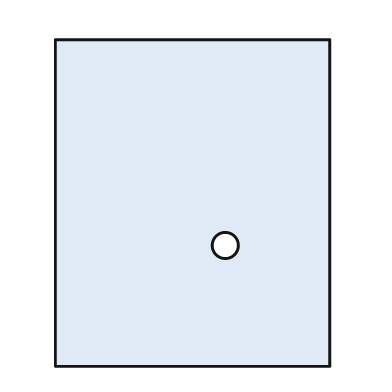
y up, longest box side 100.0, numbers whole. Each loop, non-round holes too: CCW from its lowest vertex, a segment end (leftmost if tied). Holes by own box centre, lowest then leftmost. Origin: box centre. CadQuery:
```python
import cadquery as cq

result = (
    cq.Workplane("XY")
    .moveTo(-42.0, -50.0)
    .lineTo(42.0, -50.0)
    .lineTo(42.0, 50.0)
    .lineTo(-42.0, 50.0)
    .close()
    .moveTo(10.0, -13.0)
    .circle(4.0)
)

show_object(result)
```